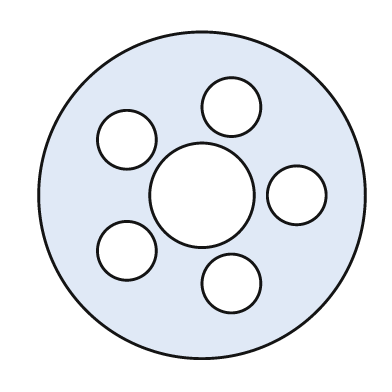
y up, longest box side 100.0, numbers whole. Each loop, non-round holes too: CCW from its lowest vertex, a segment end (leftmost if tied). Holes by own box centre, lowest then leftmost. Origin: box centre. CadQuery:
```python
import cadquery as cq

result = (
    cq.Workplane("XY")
    .moveTo(0.0, 0.0)
    .circle(50.0)
    .moveTo(9.0, -27.0)
    .circle(9.0)
    .moveTo(-23.0, -17.0)
    .circle(9.0)
    .moveTo(0.0, 0.0)
    .circle(16.0)
    .moveTo(29.0, 0.0)
    .circle(9.0)
    .moveTo(-23.0, 17.0)
    .circle(9.0)
    .moveTo(9.0, 27.0)
    .circle(9.0)
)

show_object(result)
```